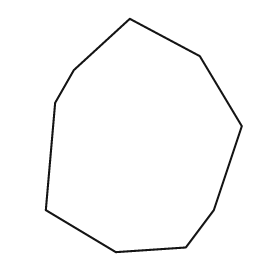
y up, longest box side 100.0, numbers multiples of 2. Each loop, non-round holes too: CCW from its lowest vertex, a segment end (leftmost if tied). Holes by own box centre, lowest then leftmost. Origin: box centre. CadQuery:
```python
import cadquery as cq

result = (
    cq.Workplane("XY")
    .moveTo(-12.0, -50.0)
    .lineTo(18.0, -48.0)
    .lineTo(30.0, -32.0)
    .lineTo(42.0, 4.0)
    .lineTo(24.0, 34.0)
    .lineTo(-6.0, 50.0)
    .lineTo(-30.0, 28.0)
    .lineTo(-38.0, 14.0)
    .lineTo(-42.0, -32.0)
    .close()
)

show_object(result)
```